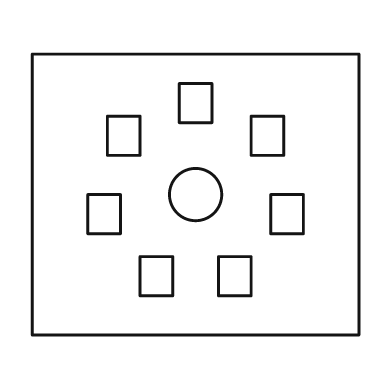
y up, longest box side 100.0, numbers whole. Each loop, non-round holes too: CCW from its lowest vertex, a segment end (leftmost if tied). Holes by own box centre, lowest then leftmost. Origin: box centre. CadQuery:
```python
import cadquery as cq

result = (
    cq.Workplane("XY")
    .moveTo(-50.0, -43.0)
    .lineTo(50.0, -43.0)
    .lineTo(50.0, 43.0)
    .lineTo(-50.0, 43.0)
    .close()
    .moveTo(-17.0, -31.0)
    .lineTo(-7.0, -31.0)
    .lineTo(-7.0, -19.0)
    .lineTo(-17.0, -19.0)
    .close()
    .moveTo(7.0, -31.0)
    .lineTo(17.0, -31.0)
    .lineTo(17.0, -19.0)
    .lineTo(7.0, -19.0)
    .close()
    .moveTo(-33.0, -12.0)
    .lineTo(-23.0, -12.0)
    .lineTo(-23.0, 0.0)
    .lineTo(-33.0, 0.0)
    .close()
    .moveTo(23.0, -12.0)
    .lineTo(33.0, -12.0)
    .lineTo(33.0, 0.0)
    .lineTo(23.0, 0.0)
    .close()
    .moveTo(0.0, 0.0)
    .circle(8.0)
    .moveTo(-27.0, 12.0)
    .lineTo(-17.0, 12.0)
    .lineTo(-17.0, 24.0)
    .lineTo(-27.0, 24.0)
    .close()
    .moveTo(17.0, 12.0)
    .lineTo(27.0, 12.0)
    .lineTo(27.0, 24.0)
    .lineTo(17.0, 24.0)
    .close()
    .moveTo(-5.0, 22.0)
    .lineTo(5.0, 22.0)
    .lineTo(5.0, 34.0)
    .lineTo(-5.0, 34.0)
    .close()
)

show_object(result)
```